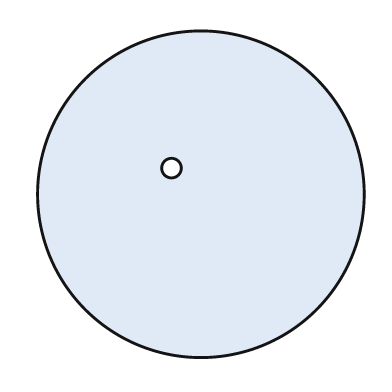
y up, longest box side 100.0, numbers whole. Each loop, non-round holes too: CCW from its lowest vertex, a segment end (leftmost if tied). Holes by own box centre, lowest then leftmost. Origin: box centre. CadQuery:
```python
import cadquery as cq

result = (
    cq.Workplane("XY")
    .moveTo(0.0, 0.0)
    .circle(50.0)
    .moveTo(-9.0, 8.0)
    .circle(3.0)
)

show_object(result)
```